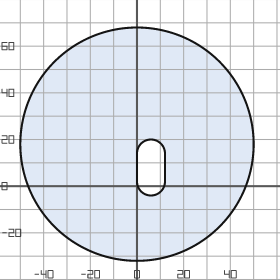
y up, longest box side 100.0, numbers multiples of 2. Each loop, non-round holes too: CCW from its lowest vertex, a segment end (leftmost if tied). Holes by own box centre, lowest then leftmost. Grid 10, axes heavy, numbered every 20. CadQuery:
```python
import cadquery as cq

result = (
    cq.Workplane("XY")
    .moveTo(0.0, 18.0)
    .circle(50.0)
    .moveTo(0.0, 2.0)
    .threePointArc((6.0, -4.0), (12.0, 2.0))
    .lineTo(12.0, 14.0)
    .threePointArc((6.0, 20.0), (0.0, 14.0))
    .close()
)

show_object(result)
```